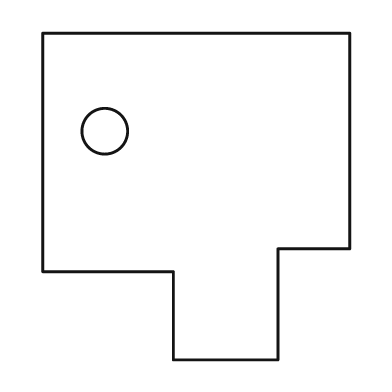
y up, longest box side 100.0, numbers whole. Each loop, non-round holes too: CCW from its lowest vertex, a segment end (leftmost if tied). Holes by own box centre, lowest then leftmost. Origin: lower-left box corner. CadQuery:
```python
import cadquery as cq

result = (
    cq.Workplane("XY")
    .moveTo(40.0, 0.0)
    .lineTo(72.0, 0.0)
    .lineTo(72.0, 34.0)
    .lineTo(94.0, 34.0)
    .lineTo(94.0, 100.0)
    .lineTo(0.0, 100.0)
    .lineTo(0.0, 27.0)
    .lineTo(40.0, 27.0)
    .close()
    .moveTo(19.0, 70.0)
    .circle(7.0)
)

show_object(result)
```